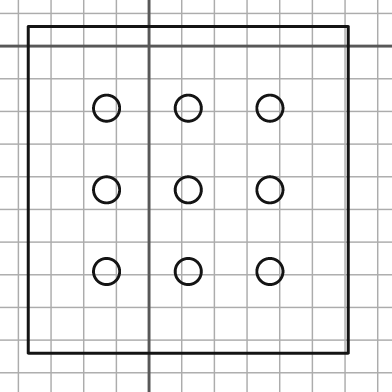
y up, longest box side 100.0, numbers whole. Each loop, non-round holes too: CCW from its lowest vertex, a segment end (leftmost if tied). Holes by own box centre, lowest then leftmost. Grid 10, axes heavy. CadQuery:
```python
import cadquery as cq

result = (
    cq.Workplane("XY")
    .moveTo(-37.0, -94.0)
    .lineTo(61.0, -94.0)
    .lineTo(61.0, 6.0)
    .lineTo(-37.0, 6.0)
    .close()
    .moveTo(-13.0, -69.0)
    .circle(4.0)
    .moveTo(12.0, -69.0)
    .circle(4.0)
    .moveTo(37.0, -69.0)
    .circle(4.0)
    .moveTo(-13.0, -44.0)
    .circle(4.0)
    .moveTo(12.0, -44.0)
    .circle(4.0)
    .moveTo(37.0, -44.0)
    .circle(4.0)
    .moveTo(-13.0, -19.0)
    .circle(4.0)
    .moveTo(12.0, -19.0)
    .circle(4.0)
    .moveTo(37.0, -19.0)
    .circle(4.0)
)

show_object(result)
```